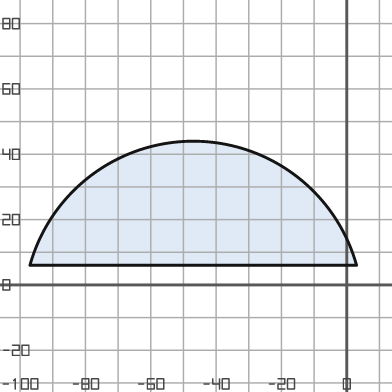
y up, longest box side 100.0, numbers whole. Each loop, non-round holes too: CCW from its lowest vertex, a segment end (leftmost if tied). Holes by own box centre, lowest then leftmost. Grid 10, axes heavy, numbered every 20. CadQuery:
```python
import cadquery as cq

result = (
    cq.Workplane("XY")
    .moveTo(-97.0, 6.0)
    .lineTo(3.0, 6.0)
    .threePointArc((-47.0, 44.0), (-97.0, 6.0))
    .close()
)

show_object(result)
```